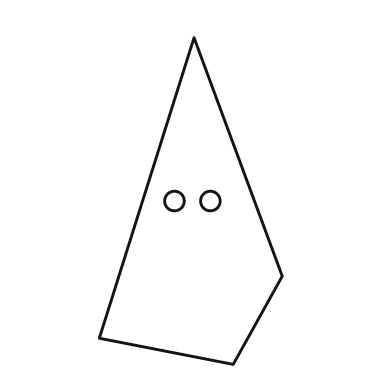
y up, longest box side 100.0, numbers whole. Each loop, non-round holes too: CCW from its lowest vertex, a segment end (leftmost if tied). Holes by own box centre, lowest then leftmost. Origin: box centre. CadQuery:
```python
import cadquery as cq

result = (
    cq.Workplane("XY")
    .moveTo(13.0, -50.0)
    .lineTo(28.0, -23.0)
    .lineTo(1.0, 50.0)
    .lineTo(-28.0, -42.0)
    .close()
    .moveTo(-5.0, 0.0)
    .circle(3.0)
    .moveTo(6.0, 0.0)
    .circle(3.0)
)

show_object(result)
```